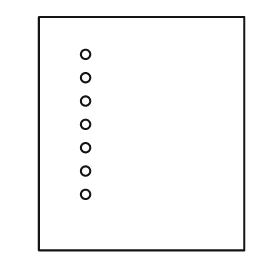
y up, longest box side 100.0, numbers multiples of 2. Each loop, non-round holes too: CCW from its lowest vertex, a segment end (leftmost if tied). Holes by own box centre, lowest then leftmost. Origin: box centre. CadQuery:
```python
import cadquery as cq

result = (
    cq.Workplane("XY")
    .moveTo(-44.0, -50.0)
    .lineTo(44.0, -50.0)
    .lineTo(44.0, 50.0)
    .lineTo(-44.0, 50.0)
    .close()
    .moveTo(-24.0, -26.0)
    .circle(2.0)
    .moveTo(-24.0, -16.0)
    .circle(2.0)
    .moveTo(-24.0, -6.0)
    .circle(2.0)
    .moveTo(-24.0, 4.0)
    .circle(2.0)
    .moveTo(-24.0, 14.0)
    .circle(2.0)
    .moveTo(-24.0, 24.0)
    .circle(2.0)
    .moveTo(-24.0, 34.0)
    .circle(2.0)
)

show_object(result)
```